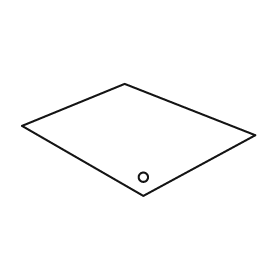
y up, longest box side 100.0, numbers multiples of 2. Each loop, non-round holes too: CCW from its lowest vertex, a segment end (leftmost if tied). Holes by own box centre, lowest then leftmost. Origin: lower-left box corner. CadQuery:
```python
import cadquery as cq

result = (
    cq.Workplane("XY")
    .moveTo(52.0, 0.0)
    .lineTo(100.0, 26.0)
    .lineTo(44.0, 48.0)
    .lineTo(0.0, 30.0)
    .close()
    .moveTo(52.0, 8.0)
    .circle(2.0)
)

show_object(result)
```